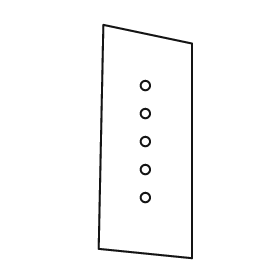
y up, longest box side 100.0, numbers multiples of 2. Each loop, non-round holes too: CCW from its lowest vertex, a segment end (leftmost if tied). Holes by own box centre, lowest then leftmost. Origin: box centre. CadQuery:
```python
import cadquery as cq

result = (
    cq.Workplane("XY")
    .moveTo(20.0, -50.0)
    .lineTo(20.0, 42.0)
    .lineTo(-18.0, 50.0)
    .lineTo(-20.0, -46.0)
    .close()
    .moveTo(0.0, -24.0)
    .circle(2.0)
    .moveTo(0.0, -12.0)
    .circle(2.0)
    .moveTo(0.0, 0.0)
    .circle(2.0)
    .moveTo(0.0, 12.0)
    .circle(2.0)
    .moveTo(0.0, 24.0)
    .circle(2.0)
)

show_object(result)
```